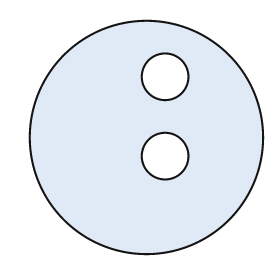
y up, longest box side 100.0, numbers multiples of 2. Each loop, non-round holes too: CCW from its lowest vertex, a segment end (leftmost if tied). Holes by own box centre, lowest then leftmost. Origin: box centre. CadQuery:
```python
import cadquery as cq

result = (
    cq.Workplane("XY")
    .moveTo(0.0, 0.0)
    .circle(50.0)
    .moveTo(8.0, -8.0)
    .circle(10.0)
    .moveTo(8.0, 26.0)
    .circle(10.0)
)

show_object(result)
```